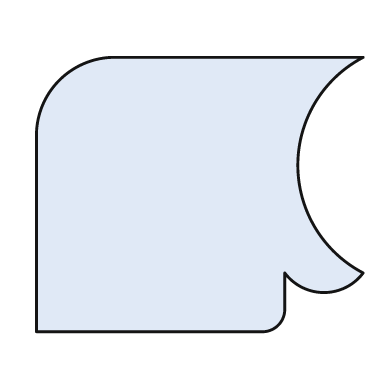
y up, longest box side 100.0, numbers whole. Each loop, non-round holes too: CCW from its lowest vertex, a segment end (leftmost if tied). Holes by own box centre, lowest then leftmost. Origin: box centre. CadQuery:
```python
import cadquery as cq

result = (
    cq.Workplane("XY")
    .moveTo(-50.0, -42.0)
    .lineTo(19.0, -42.0)
    .threePointArc((24.0, -40.0), (26.0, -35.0))
    .lineTo(26.0, -24.0)
    .threePointArc((38.0, -30.0), (50.0, -24.0))
    .threePointArc((30.0, 9.0), (50.0, 42.0))
    .lineTo(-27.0, 42.0)
    .threePointArc((-43.0, 35.0), (-50.0, 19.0))
    .close()
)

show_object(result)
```